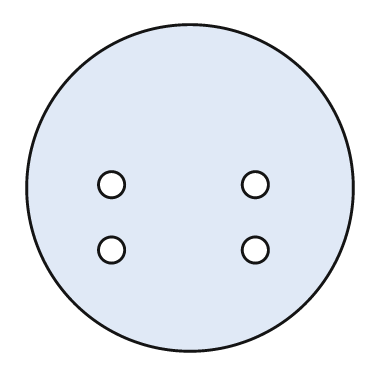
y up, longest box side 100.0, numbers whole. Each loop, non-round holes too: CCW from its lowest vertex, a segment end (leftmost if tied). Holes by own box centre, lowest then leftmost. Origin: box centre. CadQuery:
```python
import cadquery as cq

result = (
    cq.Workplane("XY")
    .moveTo(0.0, 0.0)
    .circle(50.0)
    .moveTo(-24.0, -19.0)
    .circle(4.0)
    .moveTo(20.0, -19.0)
    .circle(4.0)
    .moveTo(-24.0, 1.0)
    .circle(4.0)
    .moveTo(20.0, 1.0)
    .circle(4.0)
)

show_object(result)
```